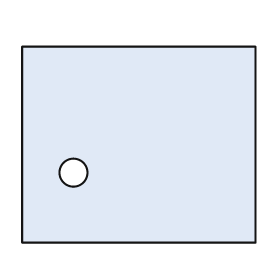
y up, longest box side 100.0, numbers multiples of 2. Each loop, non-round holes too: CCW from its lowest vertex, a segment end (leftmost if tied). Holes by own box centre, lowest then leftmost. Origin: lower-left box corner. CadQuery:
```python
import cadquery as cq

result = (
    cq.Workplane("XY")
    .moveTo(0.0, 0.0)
    .lineTo(100.0, 0.0)
    .lineTo(100.0, 84.0)
    .lineTo(0.0, 84.0)
    .close()
    .moveTo(22.0, 30.0)
    .circle(6.0)
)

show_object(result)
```